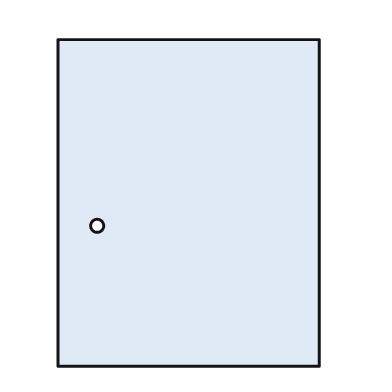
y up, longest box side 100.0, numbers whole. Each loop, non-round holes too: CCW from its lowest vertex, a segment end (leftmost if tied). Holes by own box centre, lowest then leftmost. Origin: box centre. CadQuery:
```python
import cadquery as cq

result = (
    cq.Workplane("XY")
    .moveTo(-40.0, -50.0)
    .lineTo(40.0, -50.0)
    .lineTo(40.0, 50.0)
    .lineTo(-40.0, 50.0)
    .close()
    .moveTo(-28.0, -7.0)
    .circle(2.0)
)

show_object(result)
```